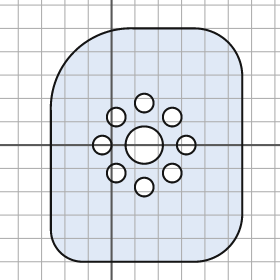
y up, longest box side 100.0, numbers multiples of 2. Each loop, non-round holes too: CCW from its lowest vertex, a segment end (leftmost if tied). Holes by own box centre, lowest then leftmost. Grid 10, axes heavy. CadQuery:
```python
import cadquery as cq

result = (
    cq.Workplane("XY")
    .moveTo(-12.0, -50.0)
    .lineTo(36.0, -50.0)
    .threePointArc((50.0, -44.0), (56.0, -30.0))
    .lineTo(56.0, 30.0)
    .threePointArc((50.0, 44.0), (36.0, 50.0))
    .lineTo(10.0, 50.0)
    .threePointArc((-16.0, 40.0), (-26.0, 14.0))
    .lineTo(-26.0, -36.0)
    .threePointArc((-22.0, -46.0), (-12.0, -50.0))
    .close()
    .moveTo(14.0, -18.0)
    .circle(4.0)
    .moveTo(2.0, -12.0)
    .circle(4.0)
    .moveTo(26.0, -12.0)
    .circle(4.0)
    .moveTo(-4.0, 0.0)
    .circle(4.0)
    .moveTo(14.0, 0.0)
    .circle(8.0)
    .moveTo(32.0, 0.0)
    .circle(4.0)
    .moveTo(2.0, 12.0)
    .circle(4.0)
    .moveTo(26.0, 12.0)
    .circle(4.0)
    .moveTo(14.0, 18.0)
    .circle(4.0)
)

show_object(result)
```